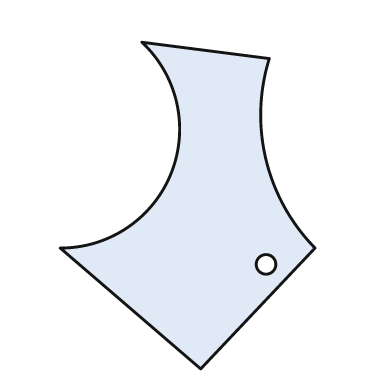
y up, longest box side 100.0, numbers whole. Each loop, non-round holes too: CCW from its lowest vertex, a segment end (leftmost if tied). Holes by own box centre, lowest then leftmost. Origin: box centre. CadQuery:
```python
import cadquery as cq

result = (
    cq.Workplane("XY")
    .moveTo(4.0, -50.0)
    .lineTo(39.0, -13.0)
    .threePointArc((24.0, 14.0), (25.0, 45.0))
    .lineTo(-14.0, 50.0)
    .threePointArc((-5.0, 10.0), (-39.0, -13.0))
    .close()
    .moveTo(24.0, -18.0)
    .circle(3.0)
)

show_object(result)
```